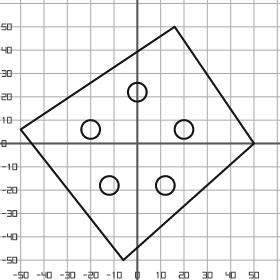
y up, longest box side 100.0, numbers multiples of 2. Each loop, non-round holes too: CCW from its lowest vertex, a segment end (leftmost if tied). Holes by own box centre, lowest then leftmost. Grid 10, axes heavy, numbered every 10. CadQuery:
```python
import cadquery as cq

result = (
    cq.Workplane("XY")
    .moveTo(-6.0, -50.0)
    .lineTo(50.0, 0.0)
    .lineTo(16.0, 50.0)
    .lineTo(-50.0, 6.0)
    .close()
    .moveTo(-12.0, -18.0)
    .circle(4.0)
    .moveTo(12.0, -18.0)
    .circle(4.0)
    .moveTo(-20.0, 6.0)
    .circle(4.0)
    .moveTo(20.0, 6.0)
    .circle(4.0)
    .moveTo(0.0, 22.0)
    .circle(4.0)
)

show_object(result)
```